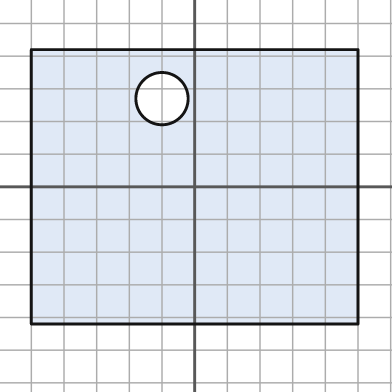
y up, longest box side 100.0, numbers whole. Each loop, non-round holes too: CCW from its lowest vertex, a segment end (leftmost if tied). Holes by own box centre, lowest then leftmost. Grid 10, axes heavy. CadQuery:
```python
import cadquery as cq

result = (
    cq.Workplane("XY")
    .moveTo(-50.0, -42.0)
    .lineTo(50.0, -42.0)
    .lineTo(50.0, 42.0)
    .lineTo(-50.0, 42.0)
    .close()
    .moveTo(-10.0, 27.0)
    .circle(8.0)
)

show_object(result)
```